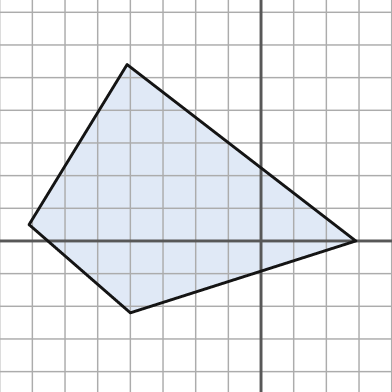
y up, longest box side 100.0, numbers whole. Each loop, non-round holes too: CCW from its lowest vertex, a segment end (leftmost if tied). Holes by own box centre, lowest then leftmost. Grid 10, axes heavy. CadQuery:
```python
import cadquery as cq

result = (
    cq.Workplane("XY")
    .moveTo(-40.0, -22.0)
    .lineTo(29.0, 0.0)
    .lineTo(-41.0, 54.0)
    .lineTo(-71.0, 5.0)
    .close()
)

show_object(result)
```